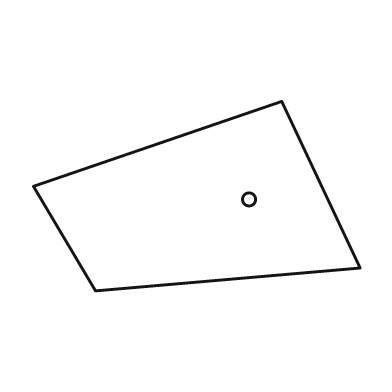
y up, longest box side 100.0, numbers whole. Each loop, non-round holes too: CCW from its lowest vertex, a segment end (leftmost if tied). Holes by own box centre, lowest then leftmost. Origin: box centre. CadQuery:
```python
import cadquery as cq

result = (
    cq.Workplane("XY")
    .moveTo(-31.0, -29.0)
    .lineTo(50.0, -22.0)
    .lineTo(26.0, 29.0)
    .lineTo(-50.0, 3.0)
    .close()
    .moveTo(16.0, -1.0)
    .circle(2.0)
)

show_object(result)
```